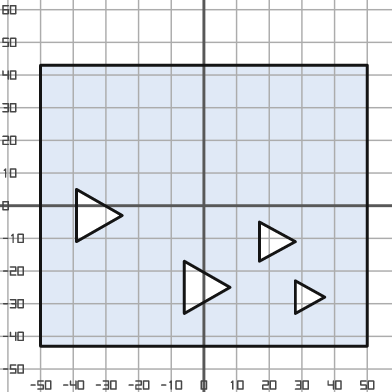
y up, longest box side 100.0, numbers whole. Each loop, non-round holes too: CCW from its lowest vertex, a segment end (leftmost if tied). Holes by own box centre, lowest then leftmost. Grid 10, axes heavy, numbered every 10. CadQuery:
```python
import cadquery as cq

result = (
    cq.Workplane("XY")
    .moveTo(-50.0, -43.0)
    .lineTo(50.0, -43.0)
    .lineTo(50.0, 43.0)
    .lineTo(-50.0, 43.0)
    .close()
    .moveTo(28.0, -33.0)
    .lineTo(37.0, -28.0)
    .lineTo(28.0, -23.0)
    .close()
    .moveTo(-6.0, -33.0)
    .lineTo(8.0, -25.0)
    .lineTo(-6.0, -17.0)
    .close()
    .moveTo(17.0, -17.0)
    .lineTo(28.0, -11.0)
    .lineTo(17.0, -5.0)
    .close()
    .moveTo(-39.0, -11.0)
    .lineTo(-25.0, -3.0)
    .lineTo(-39.0, 5.0)
    .close()
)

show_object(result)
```